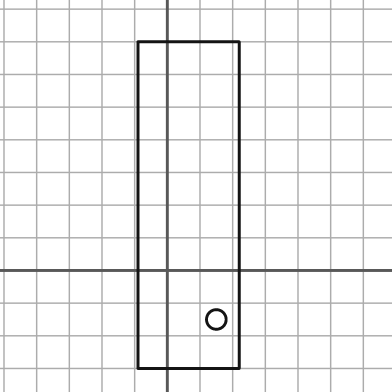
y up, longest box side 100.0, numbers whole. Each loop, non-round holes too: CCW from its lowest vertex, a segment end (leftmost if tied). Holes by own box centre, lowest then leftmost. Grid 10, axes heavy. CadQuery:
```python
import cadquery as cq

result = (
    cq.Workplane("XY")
    .moveTo(-9.0, -30.0)
    .lineTo(22.0, -30.0)
    .lineTo(22.0, 70.0)
    .lineTo(-9.0, 70.0)
    .close()
    .moveTo(15.0, -15.0)
    .circle(3.0)
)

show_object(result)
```